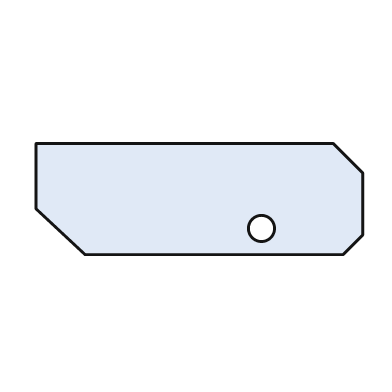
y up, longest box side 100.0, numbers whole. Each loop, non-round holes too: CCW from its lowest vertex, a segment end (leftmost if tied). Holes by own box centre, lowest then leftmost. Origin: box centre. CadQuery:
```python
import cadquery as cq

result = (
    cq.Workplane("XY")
    .moveTo(-35.0, -17.0)
    .lineTo(44.0, -17.0)
    .lineTo(50.0, -11.0)
    .lineTo(50.0, 8.0)
    .lineTo(41.0, 17.0)
    .lineTo(-50.0, 17.0)
    .lineTo(-50.0, -3.0)
    .close()
    .moveTo(19.0, -9.0)
    .circle(4.0)
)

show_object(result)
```